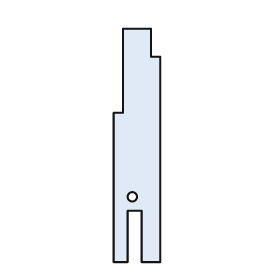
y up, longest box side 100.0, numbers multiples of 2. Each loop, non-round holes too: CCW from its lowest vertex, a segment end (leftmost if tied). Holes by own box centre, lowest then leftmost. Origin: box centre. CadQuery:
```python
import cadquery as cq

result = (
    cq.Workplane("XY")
    .moveTo(-10.0, -50.0)
    .lineTo(-4.0, -50.0)
    .lineTo(-4.0, -28.0)
    .lineTo(2.0, -28.0)
    .lineTo(2.0, -50.0)
    .lineTo(10.0, -50.0)
    .lineTo(10.0, 38.0)
    .lineTo(6.0, 38.0)
    .lineTo(6.0, 50.0)
    .lineTo(-6.0, 50.0)
    .lineTo(-6.0, 14.0)
    .lineTo(-10.0, 14.0)
    .close()
    .moveTo(-2.0, -22.0)
    .circle(2.0)
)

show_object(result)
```